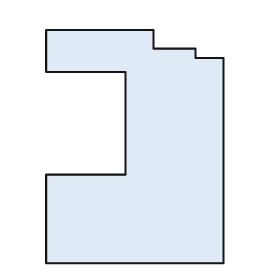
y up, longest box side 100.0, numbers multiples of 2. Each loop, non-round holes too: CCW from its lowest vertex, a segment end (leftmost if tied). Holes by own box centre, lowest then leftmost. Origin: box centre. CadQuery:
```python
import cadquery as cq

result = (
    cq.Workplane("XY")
    .moveTo(-38.0, -50.0)
    .lineTo(38.0, -50.0)
    .lineTo(38.0, 38.0)
    .lineTo(26.0, 38.0)
    .lineTo(26.0, 42.0)
    .lineTo(8.0, 42.0)
    .lineTo(8.0, 50.0)
    .lineTo(-38.0, 50.0)
    .lineTo(-38.0, 32.0)
    .lineTo(-4.0, 32.0)
    .lineTo(-4.0, -12.0)
    .lineTo(-38.0, -12.0)
    .close()
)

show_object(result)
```